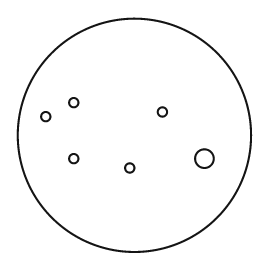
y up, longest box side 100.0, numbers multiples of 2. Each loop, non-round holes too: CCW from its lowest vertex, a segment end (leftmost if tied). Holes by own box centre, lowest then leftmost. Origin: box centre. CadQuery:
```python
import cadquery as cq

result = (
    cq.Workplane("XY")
    .moveTo(0.0, 0.0)
    .circle(50.0)
    .moveTo(-2.0, -14.0)
    .circle(2.0)
    .moveTo(-26.0, -10.0)
    .circle(2.0)
    .moveTo(30.0, -10.0)
    .circle(4.0)
    .moveTo(-38.0, 8.0)
    .circle(2.0)
    .moveTo(12.0, 10.0)
    .circle(2.0)
    .moveTo(-26.0, 14.0)
    .circle(2.0)
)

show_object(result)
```